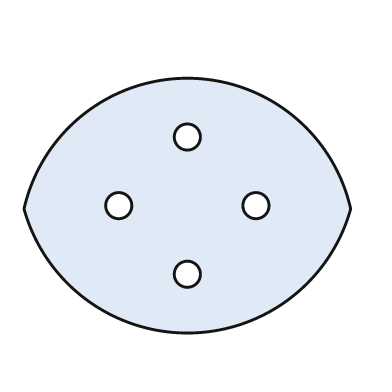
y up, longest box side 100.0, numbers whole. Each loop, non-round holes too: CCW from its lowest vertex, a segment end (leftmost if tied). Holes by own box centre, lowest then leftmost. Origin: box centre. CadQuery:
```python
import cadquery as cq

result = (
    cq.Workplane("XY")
    .moveTo(-50.0, -1.0)
    .threePointArc((0.0, -39.0), (50.0, -1.0))
    .threePointArc((0.0, 39.0), (-50.0, -1.0))
    .close()
    .moveTo(0.0, -21.0)
    .circle(4.0)
    .moveTo(-21.0, 0.0)
    .circle(4.0)
    .moveTo(21.0, 0.0)
    .circle(4.0)
    .moveTo(0.0, 21.0)
    .circle(4.0)
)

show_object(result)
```